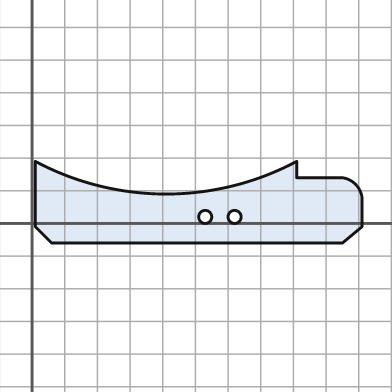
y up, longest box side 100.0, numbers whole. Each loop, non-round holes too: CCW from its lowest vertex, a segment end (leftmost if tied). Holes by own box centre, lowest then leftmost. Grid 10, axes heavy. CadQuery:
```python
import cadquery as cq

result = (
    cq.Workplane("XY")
    .moveTo(6.0, -6.0)
    .lineTo(95.0, -6.0)
    .lineTo(101.0, -1.0)
    .lineTo(101.0, 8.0)
    .threePointArc((99.0, 12.0), (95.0, 14.0))
    .lineTo(81.0, 14.0)
    .lineTo(81.0, 19.0)
    .threePointArc((41.0, 9.0), (1.0, 19.0))
    .lineTo(1.0, -1.0)
    .close()
    .moveTo(53.0, 2.0)
    .circle(2.0)
    .moveTo(62.0, 2.0)
    .circle(2.0)
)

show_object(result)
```